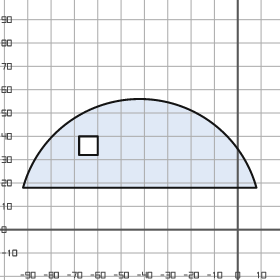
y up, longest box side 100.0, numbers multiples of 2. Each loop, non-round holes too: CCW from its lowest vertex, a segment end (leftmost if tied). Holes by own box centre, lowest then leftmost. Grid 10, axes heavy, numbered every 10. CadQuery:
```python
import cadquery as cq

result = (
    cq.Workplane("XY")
    .moveTo(-92.0, 18.0)
    .lineTo(8.0, 18.0)
    .threePointArc((-42.0, 56.0), (-92.0, 18.0))
    .close()
    .moveTo(-68.0, 32.0)
    .lineTo(-60.0, 32.0)
    .lineTo(-60.0, 40.0)
    .lineTo(-68.0, 40.0)
    .close()
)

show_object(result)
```